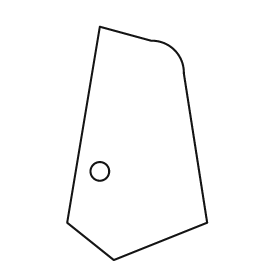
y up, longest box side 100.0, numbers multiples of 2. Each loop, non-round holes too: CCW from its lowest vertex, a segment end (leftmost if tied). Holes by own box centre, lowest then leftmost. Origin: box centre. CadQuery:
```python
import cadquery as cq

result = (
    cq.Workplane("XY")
    .moveTo(-10.0, -50.0)
    .lineTo(30.0, -34.0)
    .lineTo(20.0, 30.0)
    .threePointArc((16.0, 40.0), (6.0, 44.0))
    .lineTo(-16.0, 50.0)
    .lineTo(-30.0, -34.0)
    .close()
    .moveTo(-16.0, -12.0)
    .circle(4.0)
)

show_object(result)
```